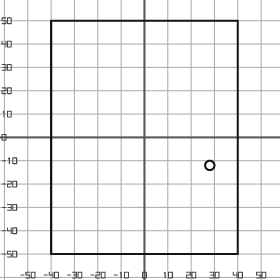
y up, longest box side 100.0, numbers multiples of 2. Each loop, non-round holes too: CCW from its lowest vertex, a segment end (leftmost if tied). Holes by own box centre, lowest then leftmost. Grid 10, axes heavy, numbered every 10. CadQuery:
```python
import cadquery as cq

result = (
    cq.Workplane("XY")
    .moveTo(-40.0, -50.0)
    .lineTo(40.0, -50.0)
    .lineTo(40.0, 50.0)
    .lineTo(-40.0, 50.0)
    .close()
    .moveTo(28.0, -12.0)
    .circle(2.0)
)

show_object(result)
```